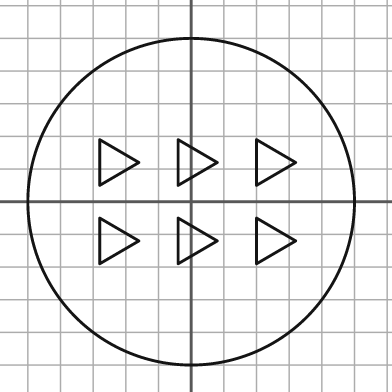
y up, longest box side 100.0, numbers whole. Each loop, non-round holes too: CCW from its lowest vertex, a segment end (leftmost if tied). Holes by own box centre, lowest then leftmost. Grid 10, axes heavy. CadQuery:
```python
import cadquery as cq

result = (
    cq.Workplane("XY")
    .moveTo(0.0, 0.0)
    .circle(50.0)
    .moveTo(-28.0, -19.0)
    .lineTo(-16.0, -12.0)
    .lineTo(-28.0, -5.0)
    .close()
    .moveTo(-4.0, -19.0)
    .lineTo(8.0, -12.0)
    .lineTo(-4.0, -5.0)
    .close()
    .moveTo(20.0, -19.0)
    .lineTo(32.0, -12.0)
    .lineTo(20.0, -5.0)
    .close()
    .moveTo(-28.0, 5.0)
    .lineTo(-16.0, 12.0)
    .lineTo(-28.0, 19.0)
    .close()
    .moveTo(-4.0, 5.0)
    .lineTo(8.0, 12.0)
    .lineTo(-4.0, 19.0)
    .close()
    .moveTo(20.0, 5.0)
    .lineTo(32.0, 12.0)
    .lineTo(20.0, 19.0)
    .close()
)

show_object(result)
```